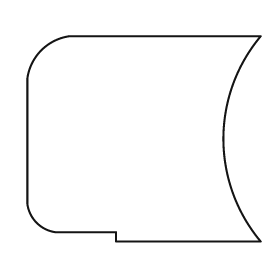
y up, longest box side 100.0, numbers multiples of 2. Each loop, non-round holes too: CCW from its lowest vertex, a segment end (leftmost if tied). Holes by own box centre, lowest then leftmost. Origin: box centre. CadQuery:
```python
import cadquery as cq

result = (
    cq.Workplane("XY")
    .moveTo(-12.0, -44.0)
    .lineTo(50.0, -44.0)
    .threePointArc((34.0, 0.0), (50.0, 44.0))
    .lineTo(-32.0, 44.0)
    .threePointArc((-44.0, 38.0), (-50.0, 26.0))
    .lineTo(-50.0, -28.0)
    .threePointArc((-46.0, -36.0), (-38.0, -40.0))
    .lineTo(-12.0, -40.0)
    .close()
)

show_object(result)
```